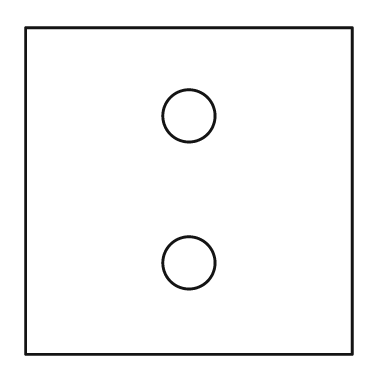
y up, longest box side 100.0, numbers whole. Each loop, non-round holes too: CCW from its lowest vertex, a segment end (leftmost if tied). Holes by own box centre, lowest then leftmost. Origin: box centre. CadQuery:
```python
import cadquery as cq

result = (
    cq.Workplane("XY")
    .moveTo(-50.0, -50.0)
    .lineTo(50.0, -50.0)
    .lineTo(50.0, 50.0)
    .lineTo(-50.0, 50.0)
    .close()
    .moveTo(0.0, -22.0)
    .circle(8.0)
    .moveTo(0.0, 23.0)
    .circle(8.0)
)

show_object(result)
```